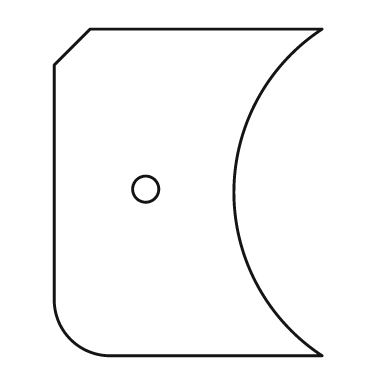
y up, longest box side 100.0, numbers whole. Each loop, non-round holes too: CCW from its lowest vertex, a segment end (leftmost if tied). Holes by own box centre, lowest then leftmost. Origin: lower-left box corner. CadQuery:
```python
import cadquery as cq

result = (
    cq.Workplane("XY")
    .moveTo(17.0, 0.0)
    .lineTo(82.0, 0.0)
    .threePointArc((55.0, 50.0), (82.0, 100.0))
    .lineTo(11.0, 100.0)
    .lineTo(0.0, 89.0)
    .lineTo(0.0, 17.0)
    .threePointArc((5.0, 5.0), (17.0, 0.0))
    .close()
    .moveTo(28.0, 51.0)
    .circle(4.0)
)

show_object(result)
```